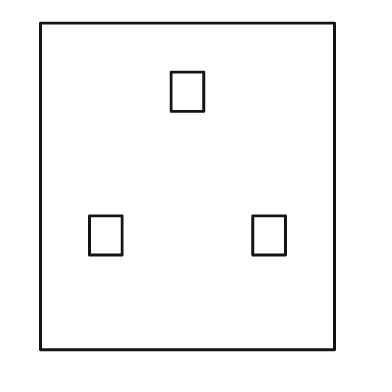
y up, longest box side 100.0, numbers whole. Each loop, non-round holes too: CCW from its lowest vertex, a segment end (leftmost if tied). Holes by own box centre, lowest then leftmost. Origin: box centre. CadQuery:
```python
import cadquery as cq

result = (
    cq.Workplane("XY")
    .moveTo(-45.0, -50.0)
    .lineTo(45.0, -50.0)
    .lineTo(45.0, 50.0)
    .lineTo(-45.0, 50.0)
    .close()
    .moveTo(-30.0, -21.0)
    .lineTo(-20.0, -21.0)
    .lineTo(-20.0, -9.0)
    .lineTo(-30.0, -9.0)
    .close()
    .moveTo(20.0, -21.0)
    .lineTo(30.0, -21.0)
    .lineTo(30.0, -9.0)
    .lineTo(20.0, -9.0)
    .close()
    .moveTo(-5.0, 23.0)
    .lineTo(5.0, 23.0)
    .lineTo(5.0, 35.0)
    .lineTo(-5.0, 35.0)
    .close()
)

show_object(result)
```